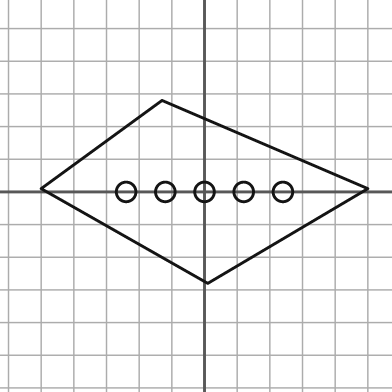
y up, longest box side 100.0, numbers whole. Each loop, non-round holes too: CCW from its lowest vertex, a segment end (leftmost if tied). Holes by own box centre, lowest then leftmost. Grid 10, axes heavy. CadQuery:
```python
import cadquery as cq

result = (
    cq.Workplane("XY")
    .moveTo(1.0, -28.0)
    .lineTo(50.0, 1.0)
    .lineTo(-13.0, 28.0)
    .lineTo(-50.0, 1.0)
    .close()
    .moveTo(-24.0, 0.0)
    .circle(3.0)
    .moveTo(-12.0, 0.0)
    .circle(3.0)
    .moveTo(0.0, 0.0)
    .circle(3.0)
    .moveTo(12.0, 0.0)
    .circle(3.0)
    .moveTo(24.0, 0.0)
    .circle(3.0)
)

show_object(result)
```